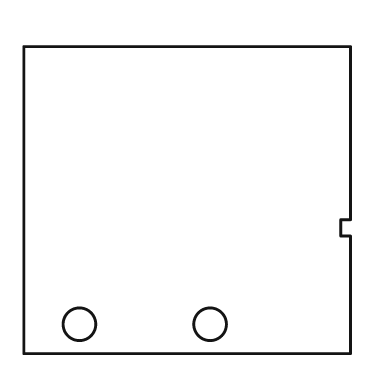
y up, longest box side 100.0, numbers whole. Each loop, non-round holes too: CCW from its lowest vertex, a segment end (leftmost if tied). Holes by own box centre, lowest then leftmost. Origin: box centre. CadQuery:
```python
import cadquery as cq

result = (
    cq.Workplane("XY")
    .moveTo(-50.0, -47.0)
    .lineTo(50.0, -47.0)
    .lineTo(50.0, -11.0)
    .lineTo(47.0, -11.0)
    .lineTo(47.0, -6.0)
    .lineTo(50.0, -6.0)
    .lineTo(50.0, 47.0)
    .lineTo(-50.0, 47.0)
    .close()
    .moveTo(-33.0, -38.0)
    .circle(5.0)
    .moveTo(7.0, -38.0)
    .circle(5.0)
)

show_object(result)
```